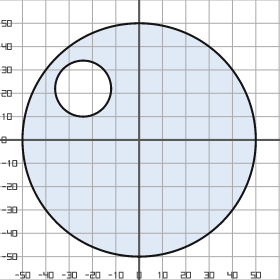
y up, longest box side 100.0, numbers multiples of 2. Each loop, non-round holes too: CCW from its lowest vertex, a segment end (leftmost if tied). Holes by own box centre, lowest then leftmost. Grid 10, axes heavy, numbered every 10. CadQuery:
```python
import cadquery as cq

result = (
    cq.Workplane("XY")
    .moveTo(0.0, 0.0)
    .circle(50.0)
    .moveTo(-24.0, 22.0)
    .circle(12.0)
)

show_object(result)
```